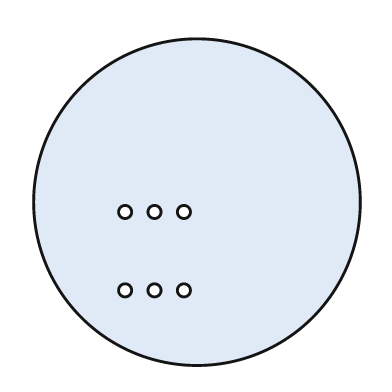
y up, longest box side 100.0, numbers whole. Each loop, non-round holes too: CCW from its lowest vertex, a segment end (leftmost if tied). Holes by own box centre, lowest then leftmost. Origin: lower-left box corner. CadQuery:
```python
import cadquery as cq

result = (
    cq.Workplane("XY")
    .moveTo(50.0, 50.0)
    .circle(50.0)
    .moveTo(28.0, 23.0)
    .circle(2.0)
    .moveTo(37.0, 23.0)
    .circle(2.0)
    .moveTo(46.0, 23.0)
    .circle(2.0)
    .moveTo(28.0, 47.0)
    .circle(2.0)
    .moveTo(37.0, 47.0)
    .circle(2.0)
    .moveTo(46.0, 47.0)
    .circle(2.0)
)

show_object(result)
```